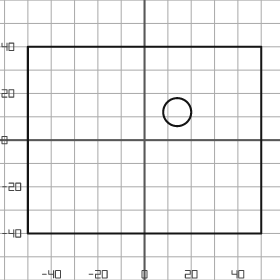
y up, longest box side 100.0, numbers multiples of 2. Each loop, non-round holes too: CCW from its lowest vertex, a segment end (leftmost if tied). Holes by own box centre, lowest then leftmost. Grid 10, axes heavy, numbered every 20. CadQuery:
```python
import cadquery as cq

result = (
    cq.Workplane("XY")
    .moveTo(-50.0, -40.0)
    .lineTo(50.0, -40.0)
    .lineTo(50.0, 40.0)
    .lineTo(-50.0, 40.0)
    .close()
    .moveTo(14.0, 12.0)
    .circle(6.0)
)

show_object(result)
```